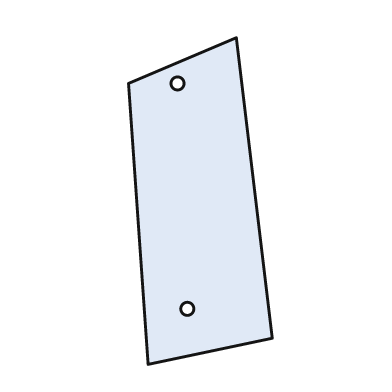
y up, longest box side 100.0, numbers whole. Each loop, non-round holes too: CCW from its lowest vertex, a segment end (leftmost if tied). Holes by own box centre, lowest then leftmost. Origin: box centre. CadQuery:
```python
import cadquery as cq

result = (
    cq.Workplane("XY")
    .moveTo(-16.0, -50.0)
    .lineTo(22.0, -42.0)
    .lineTo(11.0, 50.0)
    .lineTo(-22.0, 36.0)
    .close()
    .moveTo(-4.0, -33.0)
    .circle(2.0)
    .moveTo(-7.0, 36.0)
    .circle(2.0)
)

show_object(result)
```